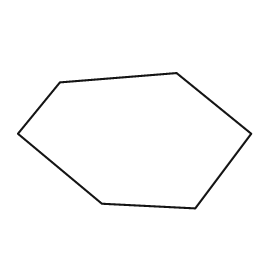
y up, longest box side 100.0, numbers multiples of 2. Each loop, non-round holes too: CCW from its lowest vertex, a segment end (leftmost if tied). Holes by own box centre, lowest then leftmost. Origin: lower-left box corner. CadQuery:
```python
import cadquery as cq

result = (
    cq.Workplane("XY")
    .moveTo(76.0, 0.0)
    .lineTo(100.0, 32.0)
    .lineTo(68.0, 58.0)
    .lineTo(18.0, 54.0)
    .lineTo(0.0, 32.0)
    .lineTo(36.0, 2.0)
    .close()
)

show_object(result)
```